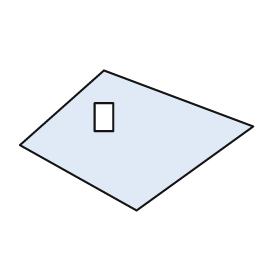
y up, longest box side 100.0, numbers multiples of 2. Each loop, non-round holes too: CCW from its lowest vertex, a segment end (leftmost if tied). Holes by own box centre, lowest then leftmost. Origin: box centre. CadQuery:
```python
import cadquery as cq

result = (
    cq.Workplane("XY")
    .moveTo(0.0, -30.0)
    .lineTo(50.0, 6.0)
    .lineTo(-14.0, 30.0)
    .lineTo(-50.0, -2.0)
    .close()
    .moveTo(-18.0, 4.0)
    .lineTo(-10.0, 4.0)
    .lineTo(-10.0, 16.0)
    .lineTo(-18.0, 16.0)
    .close()
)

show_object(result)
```